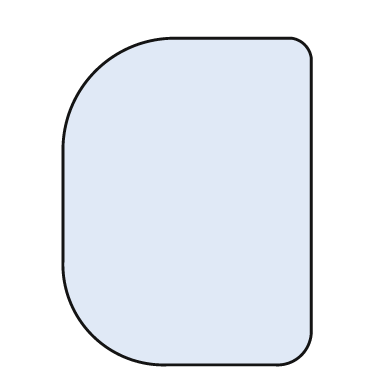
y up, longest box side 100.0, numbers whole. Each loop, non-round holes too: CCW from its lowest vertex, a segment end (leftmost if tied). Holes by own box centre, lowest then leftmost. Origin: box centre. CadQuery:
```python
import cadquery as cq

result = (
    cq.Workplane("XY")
    .moveTo(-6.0, -50.0)
    .lineTo(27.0, -50.0)
    .threePointArc((35.0, -47.0), (38.0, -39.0))
    .lineTo(38.0, 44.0)
    .threePointArc((36.0, 48.0), (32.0, 50.0))
    .lineTo(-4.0, 50.0)
    .threePointArc((-28.0, 40.0), (-38.0, 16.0))
    .lineTo(-38.0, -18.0)
    .threePointArc((-29.0, -41.0), (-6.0, -50.0))
    .close()
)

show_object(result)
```